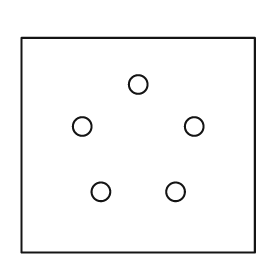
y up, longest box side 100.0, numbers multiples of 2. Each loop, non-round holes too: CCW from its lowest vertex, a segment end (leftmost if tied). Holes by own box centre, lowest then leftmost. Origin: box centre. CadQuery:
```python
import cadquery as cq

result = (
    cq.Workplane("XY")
    .moveTo(-50.0, -46.0)
    .lineTo(50.0, -46.0)
    .lineTo(50.0, 46.0)
    .lineTo(-50.0, 46.0)
    .close()
    .moveTo(-16.0, -20.0)
    .circle(4.0)
    .moveTo(16.0, -20.0)
    .circle(4.0)
    .moveTo(-24.0, 8.0)
    .circle(4.0)
    .moveTo(24.0, 8.0)
    .circle(4.0)
    .moveTo(0.0, 26.0)
    .circle(4.0)
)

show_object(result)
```